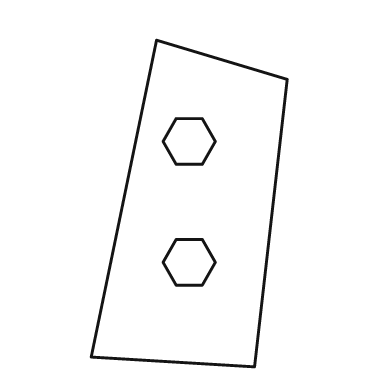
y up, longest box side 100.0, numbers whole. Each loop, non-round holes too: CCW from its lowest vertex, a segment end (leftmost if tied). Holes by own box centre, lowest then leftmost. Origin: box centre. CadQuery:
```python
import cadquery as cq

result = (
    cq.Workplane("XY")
    .moveTo(20.0, -50.0)
    .lineTo(30.0, 38.0)
    .lineTo(-10.0, 50.0)
    .lineTo(-30.0, -47.0)
    .close()
    .moveTo(-4.0, -25.0)
    .lineTo(4.0, -25.0)
    .lineTo(8.0, -18.0)
    .lineTo(4.0, -11.0)
    .lineTo(-4.0, -11.0)
    .lineTo(-8.0, -18.0)
    .close()
    .moveTo(-4.0, 12.0)
    .lineTo(4.0, 12.0)
    .lineTo(8.0, 19.0)
    .lineTo(4.0, 26.0)
    .lineTo(-4.0, 26.0)
    .lineTo(-8.0, 19.0)
    .close()
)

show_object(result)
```